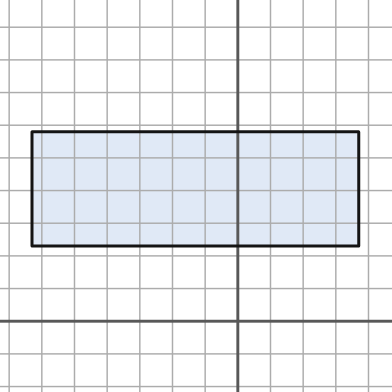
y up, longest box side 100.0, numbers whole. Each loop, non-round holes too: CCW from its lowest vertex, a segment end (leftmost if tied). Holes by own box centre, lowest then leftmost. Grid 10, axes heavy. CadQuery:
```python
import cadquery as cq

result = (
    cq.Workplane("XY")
    .moveTo(-63.0, 23.0)
    .lineTo(37.0, 23.0)
    .lineTo(37.0, 58.0)
    .lineTo(-63.0, 58.0)
    .close()
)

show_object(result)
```